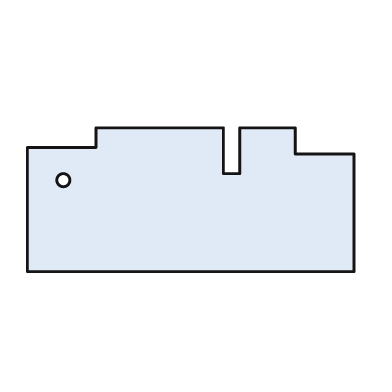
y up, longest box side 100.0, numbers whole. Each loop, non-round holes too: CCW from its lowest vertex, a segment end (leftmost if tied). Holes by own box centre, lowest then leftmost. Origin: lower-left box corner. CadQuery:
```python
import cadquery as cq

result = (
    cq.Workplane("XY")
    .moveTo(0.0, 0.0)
    .lineTo(100.0, 0.0)
    .lineTo(100.0, 36.0)
    .lineTo(82.0, 36.0)
    .lineTo(82.0, 44.0)
    .lineTo(65.0, 44.0)
    .lineTo(65.0, 30.0)
    .lineTo(60.0, 30.0)
    .lineTo(60.0, 44.0)
    .lineTo(21.0, 44.0)
    .lineTo(21.0, 38.0)
    .lineTo(0.0, 38.0)
    .close()
    .moveTo(11.0, 28.0)
    .circle(2.0)
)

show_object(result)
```